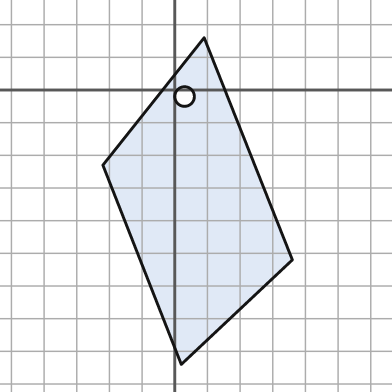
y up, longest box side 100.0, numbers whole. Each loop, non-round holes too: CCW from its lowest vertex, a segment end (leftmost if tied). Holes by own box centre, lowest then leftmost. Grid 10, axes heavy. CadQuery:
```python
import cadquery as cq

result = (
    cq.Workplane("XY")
    .moveTo(2.0, -84.0)
    .lineTo(36.0, -52.0)
    .lineTo(9.0, 16.0)
    .lineTo(-22.0, -23.0)
    .close()
    .moveTo(3.0, -2.0)
    .circle(3.0)
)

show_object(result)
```